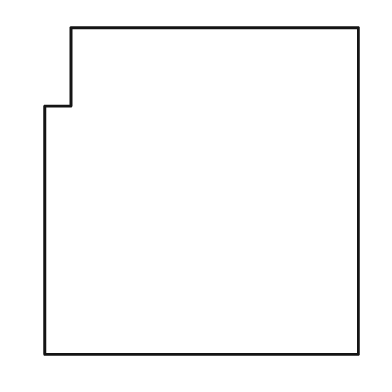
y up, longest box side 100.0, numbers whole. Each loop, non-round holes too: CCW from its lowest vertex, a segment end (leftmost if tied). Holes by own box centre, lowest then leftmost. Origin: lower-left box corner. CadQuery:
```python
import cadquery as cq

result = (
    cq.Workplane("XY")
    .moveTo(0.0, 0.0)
    .lineTo(96.0, 0.0)
    .lineTo(96.0, 100.0)
    .lineTo(8.0, 100.0)
    .lineTo(8.0, 76.0)
    .lineTo(0.0, 76.0)
    .close()
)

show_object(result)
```